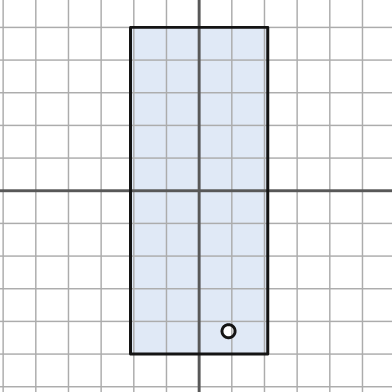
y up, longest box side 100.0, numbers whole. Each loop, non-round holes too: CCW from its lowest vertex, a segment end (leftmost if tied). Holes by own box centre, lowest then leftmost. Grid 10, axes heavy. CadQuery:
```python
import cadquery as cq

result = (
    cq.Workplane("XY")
    .moveTo(-21.0, -50.0)
    .lineTo(21.0, -50.0)
    .lineTo(21.0, 50.0)
    .lineTo(-21.0, 50.0)
    .close()
    .moveTo(9.0, -43.0)
    .circle(2.0)
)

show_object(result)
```